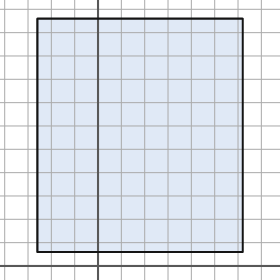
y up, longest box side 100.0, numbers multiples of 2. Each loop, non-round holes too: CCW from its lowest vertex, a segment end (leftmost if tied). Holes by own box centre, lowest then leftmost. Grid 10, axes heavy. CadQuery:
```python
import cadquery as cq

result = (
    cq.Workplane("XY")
    .moveTo(-26.0, 6.0)
    .lineTo(62.0, 6.0)
    .lineTo(62.0, 106.0)
    .lineTo(-26.0, 106.0)
    .close()
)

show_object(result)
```